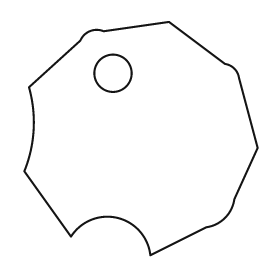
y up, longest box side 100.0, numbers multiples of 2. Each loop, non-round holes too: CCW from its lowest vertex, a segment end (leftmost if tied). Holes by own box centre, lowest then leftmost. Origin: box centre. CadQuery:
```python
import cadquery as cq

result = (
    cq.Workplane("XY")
    .moveTo(4.0, -50.0)
    .lineTo(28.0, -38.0)
    .threePointArc((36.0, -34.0), (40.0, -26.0))
    .lineTo(50.0, -4.0)
    .lineTo(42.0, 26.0)
    .threePointArc((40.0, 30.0), (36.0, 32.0))
    .lineTo(12.0, 50.0)
    .lineTo(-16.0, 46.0)
    .threePointArc((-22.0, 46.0), (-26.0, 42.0))
    .lineTo(-48.0, 22.0)
    .threePointArc((-46.0, 4.0), (-50.0, -14.0))
    .lineTo(-30.0, -42.0)
    .threePointArc((-10.0, -34.0), (4.0, -50.0))
    .close()
    .moveTo(-12.0, 28.0)
    .circle(8.0)
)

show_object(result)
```